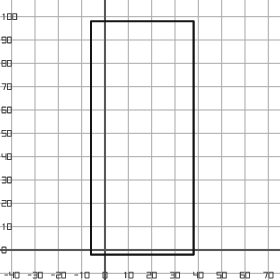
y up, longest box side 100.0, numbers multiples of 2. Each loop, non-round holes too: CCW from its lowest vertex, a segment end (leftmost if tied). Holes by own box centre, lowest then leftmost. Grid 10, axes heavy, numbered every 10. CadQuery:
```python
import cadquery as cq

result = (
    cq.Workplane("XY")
    .moveTo(-6.0, -2.0)
    .lineTo(38.0, -2.0)
    .lineTo(38.0, 98.0)
    .lineTo(-6.0, 98.0)
    .close()
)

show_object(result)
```